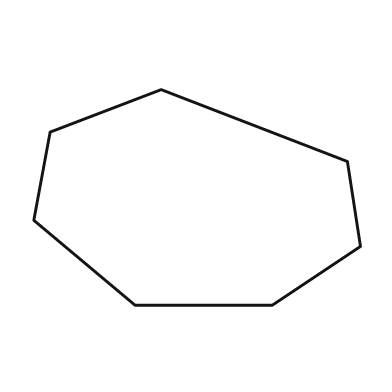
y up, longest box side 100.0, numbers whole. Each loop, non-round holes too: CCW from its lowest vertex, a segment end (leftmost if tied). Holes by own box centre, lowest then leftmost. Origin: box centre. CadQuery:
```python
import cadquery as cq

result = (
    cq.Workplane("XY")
    .moveTo(-19.0, -33.0)
    .lineTo(23.0, -33.0)
    .lineTo(50.0, -15.0)
    .lineTo(46.0, 11.0)
    .lineTo(-11.0, 33.0)
    .lineTo(-45.0, 20.0)
    .lineTo(-50.0, -7.0)
    .close()
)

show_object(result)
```